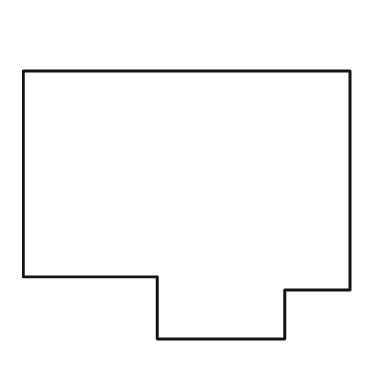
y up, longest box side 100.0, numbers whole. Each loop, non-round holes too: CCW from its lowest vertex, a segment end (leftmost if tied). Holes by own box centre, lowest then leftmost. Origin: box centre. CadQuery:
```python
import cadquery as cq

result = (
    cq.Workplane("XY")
    .moveTo(-9.0, -41.0)
    .lineTo(30.0, -41.0)
    .lineTo(30.0, -26.0)
    .lineTo(50.0, -26.0)
    .lineTo(50.0, 41.0)
    .lineTo(-50.0, 41.0)
    .lineTo(-50.0, -22.0)
    .lineTo(-9.0, -22.0)
    .close()
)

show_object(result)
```